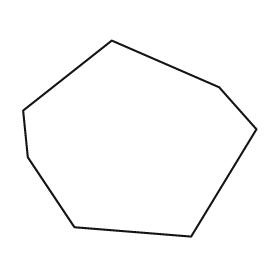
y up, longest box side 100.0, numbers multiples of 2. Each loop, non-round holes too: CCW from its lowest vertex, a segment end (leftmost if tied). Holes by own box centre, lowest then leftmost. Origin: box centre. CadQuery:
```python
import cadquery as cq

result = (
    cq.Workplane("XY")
    .moveTo(22.0, -42.0)
    .lineTo(50.0, 4.0)
    .lineTo(34.0, 22.0)
    .lineTo(-12.0, 42.0)
    .lineTo(-50.0, 12.0)
    .lineTo(-48.0, -8.0)
    .lineTo(-28.0, -38.0)
    .close()
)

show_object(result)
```